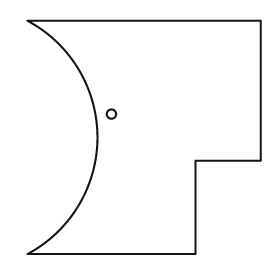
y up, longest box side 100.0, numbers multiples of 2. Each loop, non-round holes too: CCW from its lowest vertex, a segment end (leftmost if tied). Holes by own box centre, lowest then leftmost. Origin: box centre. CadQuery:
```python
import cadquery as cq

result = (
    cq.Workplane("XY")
    .moveTo(-50.0, -50.0)
    .lineTo(22.0, -50.0)
    .lineTo(22.0, -10.0)
    .lineTo(50.0, -10.0)
    .lineTo(50.0, 50.0)
    .lineTo(-50.0, 50.0)
    .threePointArc((-20.0, 0.0), (-50.0, -50.0))
    .close()
    .moveTo(-14.0, 10.0)
    .circle(2.0)
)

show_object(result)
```